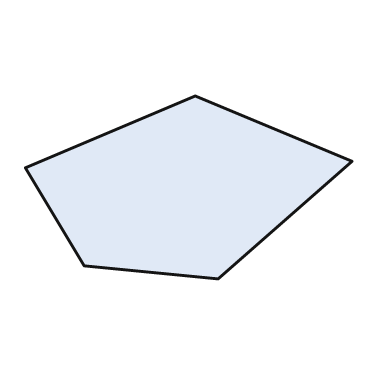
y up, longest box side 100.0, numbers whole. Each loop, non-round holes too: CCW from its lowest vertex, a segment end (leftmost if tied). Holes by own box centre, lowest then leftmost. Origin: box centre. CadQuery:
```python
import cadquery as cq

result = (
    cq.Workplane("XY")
    .moveTo(9.0, -28.0)
    .lineTo(50.0, 8.0)
    .lineTo(2.0, 28.0)
    .lineTo(-50.0, 6.0)
    .lineTo(-32.0, -24.0)
    .close()
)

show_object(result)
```